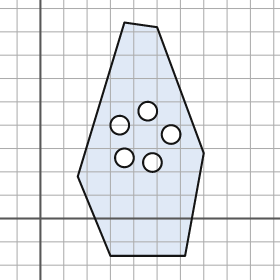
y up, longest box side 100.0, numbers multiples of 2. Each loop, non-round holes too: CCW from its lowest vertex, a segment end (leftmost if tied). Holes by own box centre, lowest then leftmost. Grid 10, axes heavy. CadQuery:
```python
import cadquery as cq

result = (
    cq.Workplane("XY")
    .moveTo(30.0, -16.0)
    .lineTo(62.0, -16.0)
    .lineTo(70.0, 28.0)
    .lineTo(50.0, 82.0)
    .lineTo(36.0, 84.0)
    .lineTo(16.0, 18.0)
    .close()
    .moveTo(48.0, 24.0)
    .circle(4.0)
    .moveTo(36.0, 26.0)
    .circle(4.0)
    .moveTo(56.0, 36.0)
    .circle(4.0)
    .moveTo(34.0, 40.0)
    .circle(4.0)
    .moveTo(46.0, 46.0)
    .circle(4.0)
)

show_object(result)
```